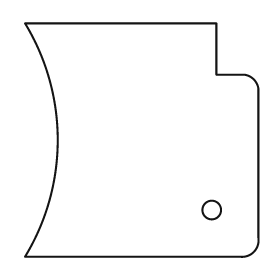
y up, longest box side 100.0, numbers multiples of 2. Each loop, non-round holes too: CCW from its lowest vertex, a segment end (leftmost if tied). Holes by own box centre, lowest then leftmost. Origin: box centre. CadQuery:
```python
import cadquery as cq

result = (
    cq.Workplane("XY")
    .moveTo(-50.0, -50.0)
    .lineTo(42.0, -50.0)
    .threePointArc((48.0, -48.0), (50.0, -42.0))
    .lineTo(50.0, 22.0)
    .threePointArc((48.0, 26.0), (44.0, 28.0))
    .lineTo(32.0, 28.0)
    .lineTo(32.0, 50.0)
    .lineTo(-50.0, 50.0)
    .threePointArc((-36.0, 0.0), (-50.0, -50.0))
    .close()
    .moveTo(30.0, -30.0)
    .circle(4.0)
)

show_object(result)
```